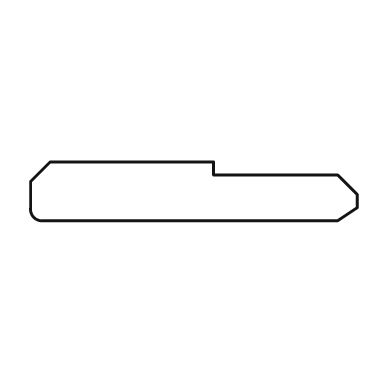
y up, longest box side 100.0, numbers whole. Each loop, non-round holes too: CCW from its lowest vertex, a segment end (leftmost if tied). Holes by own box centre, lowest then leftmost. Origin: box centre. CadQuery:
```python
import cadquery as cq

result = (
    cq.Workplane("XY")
    .moveTo(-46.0, -9.0)
    .lineTo(44.0, -9.0)
    .lineTo(50.0, -5.0)
    .lineTo(50.0, -1.0)
    .lineTo(44.0, 5.0)
    .lineTo(6.0, 5.0)
    .lineTo(6.0, 9.0)
    .lineTo(-44.0, 9.0)
    .lineTo(-50.0, 3.0)
    .lineTo(-50.0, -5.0)
    .threePointArc((-49.0, -8.0), (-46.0, -9.0))
    .close()
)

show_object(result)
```